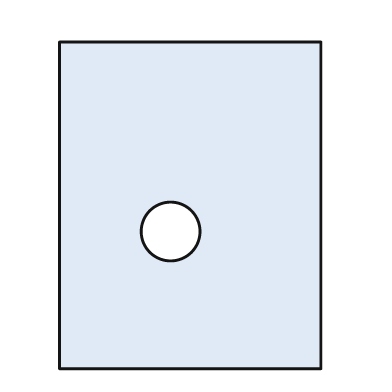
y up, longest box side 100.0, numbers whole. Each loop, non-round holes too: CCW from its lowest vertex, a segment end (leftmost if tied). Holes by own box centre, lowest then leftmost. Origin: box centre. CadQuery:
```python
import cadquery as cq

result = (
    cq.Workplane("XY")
    .moveTo(-40.0, -50.0)
    .lineTo(40.0, -50.0)
    .lineTo(40.0, 50.0)
    .lineTo(-40.0, 50.0)
    .close()
    .moveTo(-6.0, -8.0)
    .circle(9.0)
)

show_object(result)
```